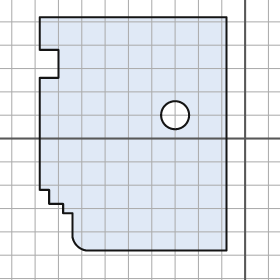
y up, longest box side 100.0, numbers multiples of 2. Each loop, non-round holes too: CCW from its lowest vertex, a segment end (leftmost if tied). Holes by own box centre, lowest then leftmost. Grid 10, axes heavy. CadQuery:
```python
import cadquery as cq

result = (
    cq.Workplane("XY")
    .moveTo(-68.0, -48.0)
    .lineTo(-8.0, -48.0)
    .lineTo(-8.0, 52.0)
    .lineTo(-88.0, 52.0)
    .lineTo(-88.0, 38.0)
    .lineTo(-80.0, 38.0)
    .lineTo(-80.0, 26.0)
    .lineTo(-88.0, 26.0)
    .lineTo(-88.0, -22.0)
    .lineTo(-84.0, -22.0)
    .lineTo(-84.0, -28.0)
    .lineTo(-78.0, -28.0)
    .lineTo(-78.0, -32.0)
    .lineTo(-74.0, -32.0)
    .lineTo(-74.0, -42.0)
    .threePointArc((-72.0, -46.0), (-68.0, -48.0))
    .close()
    .moveTo(-30.0, 10.0)
    .circle(6.0)
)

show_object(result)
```